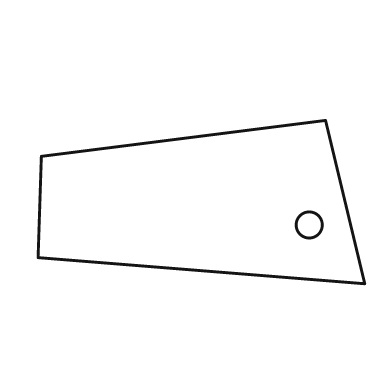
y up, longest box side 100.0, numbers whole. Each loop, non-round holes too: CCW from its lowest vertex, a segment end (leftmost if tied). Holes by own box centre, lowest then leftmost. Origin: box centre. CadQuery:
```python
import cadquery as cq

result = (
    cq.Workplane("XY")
    .moveTo(50.0, -25.0)
    .lineTo(38.0, 25.0)
    .lineTo(-49.0, 14.0)
    .lineTo(-50.0, -17.0)
    .close()
    .moveTo(33.0, -7.0)
    .circle(4.0)
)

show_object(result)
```